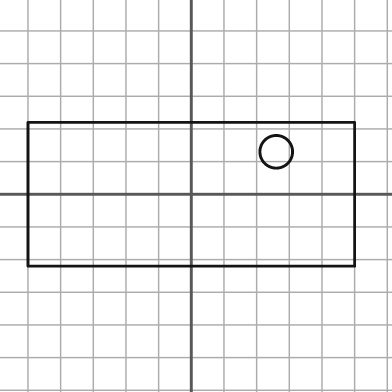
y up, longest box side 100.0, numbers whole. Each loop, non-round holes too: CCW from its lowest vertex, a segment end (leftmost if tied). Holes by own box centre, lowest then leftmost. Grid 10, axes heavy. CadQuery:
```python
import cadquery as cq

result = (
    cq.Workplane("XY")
    .moveTo(-50.0, -22.0)
    .lineTo(50.0, -22.0)
    .lineTo(50.0, 22.0)
    .lineTo(-50.0, 22.0)
    .close()
    .moveTo(26.0, 13.0)
    .circle(5.0)
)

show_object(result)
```